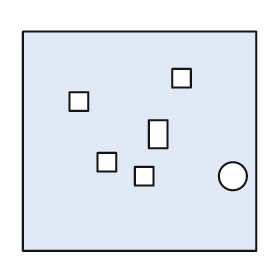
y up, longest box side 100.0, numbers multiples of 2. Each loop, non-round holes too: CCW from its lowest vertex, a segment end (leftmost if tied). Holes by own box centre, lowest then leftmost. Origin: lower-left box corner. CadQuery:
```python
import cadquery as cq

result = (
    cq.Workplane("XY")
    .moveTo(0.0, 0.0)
    .lineTo(100.0, 0.0)
    .lineTo(100.0, 94.0)
    .lineTo(0.0, 94.0)
    .close()
    .moveTo(48.0, 28.0)
    .lineTo(56.0, 28.0)
    .lineTo(56.0, 36.0)
    .lineTo(48.0, 36.0)
    .close()
    .moveTo(90.0, 32.0)
    .circle(6.0)
    .moveTo(32.0, 34.0)
    .lineTo(40.0, 34.0)
    .lineTo(40.0, 42.0)
    .lineTo(32.0, 42.0)
    .close()
    .moveTo(54.0, 44.0)
    .lineTo(62.0, 44.0)
    .lineTo(62.0, 56.0)
    .lineTo(54.0, 56.0)
    .close()
    .moveTo(20.0, 60.0)
    .lineTo(28.0, 60.0)
    .lineTo(28.0, 68.0)
    .lineTo(20.0, 68.0)
    .close()
    .moveTo(64.0, 70.0)
    .lineTo(72.0, 70.0)
    .lineTo(72.0, 78.0)
    .lineTo(64.0, 78.0)
    .close()
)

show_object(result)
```